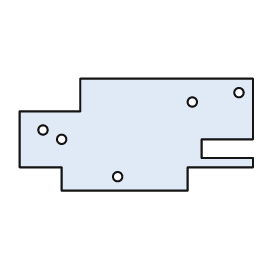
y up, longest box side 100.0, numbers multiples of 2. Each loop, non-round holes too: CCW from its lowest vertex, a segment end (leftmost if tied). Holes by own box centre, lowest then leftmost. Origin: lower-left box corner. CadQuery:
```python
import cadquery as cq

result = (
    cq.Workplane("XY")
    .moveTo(18.0, 0.0)
    .lineTo(72.0, 0.0)
    .lineTo(72.0, 10.0)
    .lineTo(100.0, 10.0)
    .lineTo(100.0, 14.0)
    .lineTo(78.0, 14.0)
    .lineTo(78.0, 22.0)
    .lineTo(100.0, 22.0)
    .lineTo(100.0, 48.0)
    .lineTo(26.0, 48.0)
    .lineTo(26.0, 34.0)
    .lineTo(0.0, 34.0)
    .lineTo(0.0, 10.0)
    .lineTo(18.0, 10.0)
    .close()
    .moveTo(42.0, 6.0)
    .circle(2.0)
    .moveTo(18.0, 22.0)
    .circle(2.0)
    .moveTo(10.0, 26.0)
    .circle(2.0)
    .moveTo(74.0, 38.0)
    .circle(2.0)
    .moveTo(94.0, 42.0)
    .circle(2.0)
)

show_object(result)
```